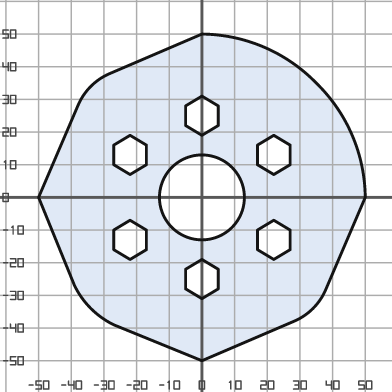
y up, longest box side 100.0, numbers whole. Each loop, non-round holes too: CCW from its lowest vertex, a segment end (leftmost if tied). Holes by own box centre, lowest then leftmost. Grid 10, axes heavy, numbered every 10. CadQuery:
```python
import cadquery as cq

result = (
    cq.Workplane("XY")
    .moveTo(0.0, -50.0)
    .lineTo(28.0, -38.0)
    .threePointArc((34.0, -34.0), (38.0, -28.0))
    .lineTo(50.0, 0.0)
    .threePointArc((46.0, 19.0), (35.0, 35.0))
    .threePointArc((19.0, 46.0), (0.0, 50.0))
    .lineTo(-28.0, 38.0)
    .threePointArc((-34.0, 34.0), (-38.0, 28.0))
    .lineTo(-50.0, 0.0)
    .lineTo(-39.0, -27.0)
    .threePointArc((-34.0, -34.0), (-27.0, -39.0))
    .close()
    .moveTo(0.0, -31.0)
    .lineTo(5.0, -28.0)
    .lineTo(5.0, -22.0)
    .lineTo(0.0, -19.0)
    .lineTo(-5.0, -22.0)
    .lineTo(-5.0, -28.0)
    .close()
    .moveTo(-22.0, -19.0)
    .lineTo(-17.0, -16.0)
    .lineTo(-17.0, -10.0)
    .lineTo(-22.0, -7.0)
    .lineTo(-27.0, -10.0)
    .lineTo(-27.0, -16.0)
    .close()
    .moveTo(22.0, -19.0)
    .lineTo(27.0, -16.0)
    .lineTo(27.0, -10.0)
    .lineTo(22.0, -7.0)
    .lineTo(17.0, -10.0)
    .lineTo(17.0, -16.0)
    .close()
    .moveTo(0.0, 0.0)
    .circle(13.0)
    .moveTo(-22.0, 7.0)
    .lineTo(-17.0, 10.0)
    .lineTo(-17.0, 16.0)
    .lineTo(-22.0, 19.0)
    .lineTo(-27.0, 16.0)
    .lineTo(-27.0, 10.0)
    .close()
    .moveTo(22.0, 7.0)
    .lineTo(27.0, 10.0)
    .lineTo(27.0, 16.0)
    .lineTo(22.0, 19.0)
    .lineTo(17.0, 16.0)
    .lineTo(17.0, 10.0)
    .close()
    .moveTo(0.0, 19.0)
    .lineTo(5.0, 22.0)
    .lineTo(5.0, 28.0)
    .lineTo(0.0, 31.0)
    .lineTo(-5.0, 28.0)
    .lineTo(-5.0, 22.0)
    .close()
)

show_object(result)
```